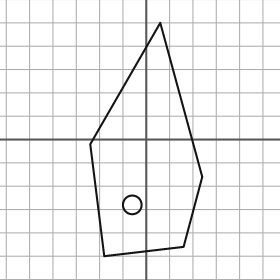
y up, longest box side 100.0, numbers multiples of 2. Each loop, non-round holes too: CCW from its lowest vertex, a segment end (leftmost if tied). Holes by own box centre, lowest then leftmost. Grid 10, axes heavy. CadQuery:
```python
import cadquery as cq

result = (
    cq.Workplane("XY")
    .moveTo(-18.0, -50.0)
    .lineTo(16.0, -46.0)
    .lineTo(24.0, -16.0)
    .lineTo(6.0, 50.0)
    .lineTo(-24.0, -2.0)
    .close()
    .moveTo(-6.0, -28.0)
    .circle(4.0)
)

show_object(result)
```